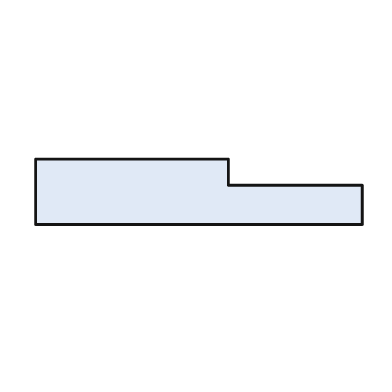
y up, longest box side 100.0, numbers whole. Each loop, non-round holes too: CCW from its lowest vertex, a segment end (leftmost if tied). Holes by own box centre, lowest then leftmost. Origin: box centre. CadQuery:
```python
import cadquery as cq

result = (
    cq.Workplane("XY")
    .moveTo(-50.0, -10.0)
    .lineTo(50.0, -10.0)
    .lineTo(50.0, 2.0)
    .lineTo(9.0, 2.0)
    .lineTo(9.0, 10.0)
    .lineTo(-50.0, 10.0)
    .close()
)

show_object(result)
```